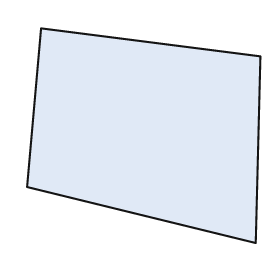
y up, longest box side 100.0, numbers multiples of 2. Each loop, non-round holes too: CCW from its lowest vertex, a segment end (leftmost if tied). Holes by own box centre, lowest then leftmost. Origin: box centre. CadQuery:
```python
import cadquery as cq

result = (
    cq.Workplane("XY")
    .moveTo(48.0, -46.0)
    .lineTo(50.0, 34.0)
    .lineTo(-44.0, 46.0)
    .lineTo(-50.0, -22.0)
    .close()
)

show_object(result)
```